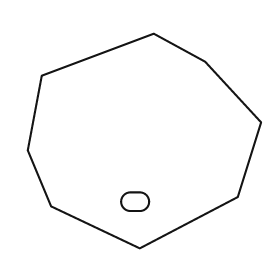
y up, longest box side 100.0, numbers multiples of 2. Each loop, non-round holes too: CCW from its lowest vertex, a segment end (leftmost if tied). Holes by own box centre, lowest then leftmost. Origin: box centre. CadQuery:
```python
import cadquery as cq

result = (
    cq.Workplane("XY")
    .moveTo(-2.0, -46.0)
    .lineTo(40.0, -24.0)
    .lineTo(50.0, 8.0)
    .lineTo(26.0, 34.0)
    .lineTo(4.0, 46.0)
    .lineTo(-44.0, 28.0)
    .lineTo(-50.0, -4.0)
    .lineTo(-40.0, -28.0)
    .close()
    .moveTo(-6.0, -30.0)
    .lineTo(-2.0, -30.0)
    .threePointArc((2.0, -26.0), (-2.0, -22.0))
    .lineTo(-6.0, -22.0)
    .threePointArc((-10.0, -26.0), (-6.0, -30.0))
    .close()
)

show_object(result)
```